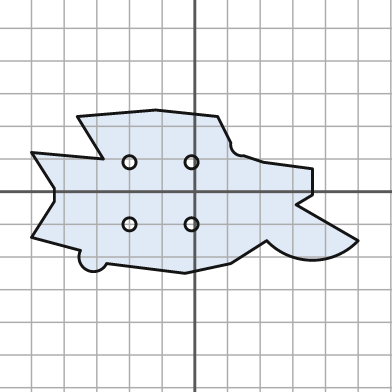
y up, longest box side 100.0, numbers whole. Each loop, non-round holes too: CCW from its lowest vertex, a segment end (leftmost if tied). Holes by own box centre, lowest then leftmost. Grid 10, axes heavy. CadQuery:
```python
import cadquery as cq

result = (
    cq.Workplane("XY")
    .moveTo(-3.0, -25.0)
    .lineTo(11.0, -22.0)
    .lineTo(22.0, -15.0)
    .threePointArc((36.0, -21.0), (50.0, -15.0))
    .lineTo(31.0, -4.0)
    .lineTo(36.0, -1.0)
    .lineTo(36.0, 7.0)
    .lineTo(21.0, 9.0)
    .lineTo(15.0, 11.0)
    .threePointArc((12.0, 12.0), (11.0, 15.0))
    .lineTo(7.0, 23.0)
    .lineTo(-12.0, 25.0)
    .lineTo(-36.0, 23.0)
    .lineTo(-28.0, 10.0)
    .lineTo(-50.0, 12.0)
    .lineTo(-43.0, 1.0)
    .lineTo(-43.0, -3.0)
    .lineTo(-50.0, -14.0)
    .lineTo(-35.0, -18.0)
    .threePointArc((-33.0, -24.0), (-27.0, -22.0))
    .close()
    .moveTo(-20.0, -10.0)
    .circle(2.0)
    .moveTo(-1.0, -10.0)
    .circle(2.0)
    .moveTo(-20.0, 9.0)
    .circle(2.0)
    .moveTo(-1.0, 9.0)
    .circle(2.0)
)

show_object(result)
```